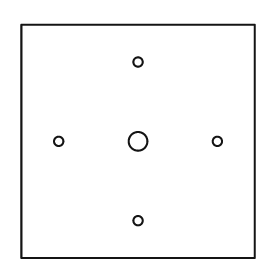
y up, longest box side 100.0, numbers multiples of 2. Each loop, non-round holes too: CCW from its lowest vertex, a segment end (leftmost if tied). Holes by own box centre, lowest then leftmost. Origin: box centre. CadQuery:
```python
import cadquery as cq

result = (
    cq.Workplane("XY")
    .moveTo(-50.0, -50.0)
    .lineTo(50.0, -50.0)
    .lineTo(50.0, 50.0)
    .lineTo(-50.0, 50.0)
    .close()
    .moveTo(0.0, -34.0)
    .circle(2.0)
    .moveTo(-34.0, 0.0)
    .circle(2.0)
    .moveTo(0.0, 0.0)
    .circle(4.0)
    .moveTo(34.0, 0.0)
    .circle(2.0)
    .moveTo(0.0, 34.0)
    .circle(2.0)
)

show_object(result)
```